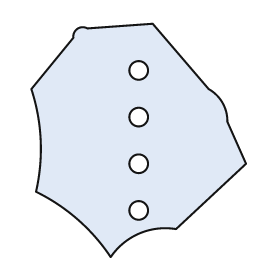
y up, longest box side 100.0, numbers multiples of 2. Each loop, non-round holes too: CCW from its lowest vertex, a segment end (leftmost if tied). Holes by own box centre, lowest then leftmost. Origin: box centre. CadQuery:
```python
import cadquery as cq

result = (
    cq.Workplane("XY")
    .moveTo(-12.0, -50.0)
    .threePointArc((0.0, -40.0), (16.0, -38.0))
    .lineTo(46.0, -10.0)
    .lineTo(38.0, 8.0)
    .threePointArc((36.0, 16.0), (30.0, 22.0))
    .lineTo(6.0, 50.0)
    .lineTo(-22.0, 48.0)
    .threePointArc((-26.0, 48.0), (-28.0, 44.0))
    .lineTo(-46.0, 22.0)
    .threePointArc((-42.0, 0.0), (-44.0, -22.0))
    .threePointArc((-26.0, -34.0), (-12.0, -50.0))
    .close()
    .moveTo(0.0, -30.0)
    .circle(4.0)
    .moveTo(0.0, -10.0)
    .circle(4.0)
    .moveTo(0.0, 10.0)
    .circle(4.0)
    .moveTo(0.0, 30.0)
    .circle(4.0)
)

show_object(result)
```